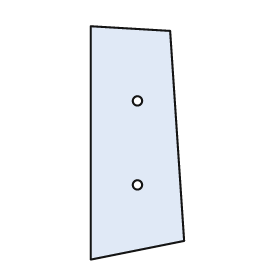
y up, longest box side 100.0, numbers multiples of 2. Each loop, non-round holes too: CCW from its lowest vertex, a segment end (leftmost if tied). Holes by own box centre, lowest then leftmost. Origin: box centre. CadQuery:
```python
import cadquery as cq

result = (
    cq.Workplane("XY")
    .moveTo(-20.0, -50.0)
    .lineTo(20.0, -42.0)
    .lineTo(14.0, 48.0)
    .lineTo(-20.0, 50.0)
    .close()
    .moveTo(0.0, -18.0)
    .circle(2.0)
    .moveTo(0.0, 18.0)
    .circle(2.0)
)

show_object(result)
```